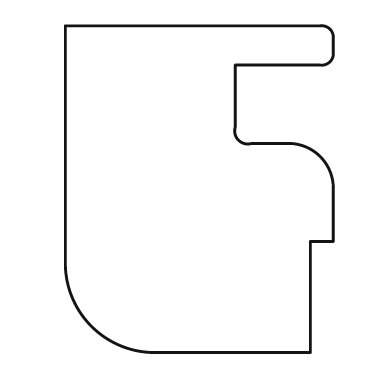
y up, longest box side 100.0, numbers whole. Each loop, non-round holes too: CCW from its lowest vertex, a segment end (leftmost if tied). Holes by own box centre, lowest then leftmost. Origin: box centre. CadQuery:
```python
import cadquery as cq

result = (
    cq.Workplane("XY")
    .moveTo(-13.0, -50.0)
    .lineTo(34.0, -50.0)
    .lineTo(34.0, -16.0)
    .lineTo(41.0, -16.0)
    .lineTo(41.0, 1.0)
    .threePointArc((37.0, 10.0), (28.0, 14.0))
    .lineTo(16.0, 14.0)
    .threePointArc((12.0, 15.0), (11.0, 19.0))
    .lineTo(11.0, 38.0)
    .lineTo(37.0, 38.0)
    .threePointArc((40.0, 39.0), (41.0, 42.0))
    .lineTo(41.0, 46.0)
    .threePointArc((40.0, 49.0), (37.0, 50.0))
    .lineTo(-41.0, 50.0)
    .lineTo(-41.0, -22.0)
    .threePointArc((-33.0, -42.0), (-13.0, -50.0))
    .close()
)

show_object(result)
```